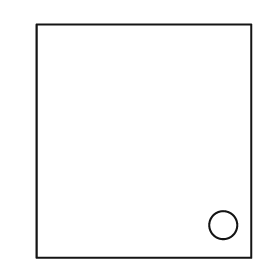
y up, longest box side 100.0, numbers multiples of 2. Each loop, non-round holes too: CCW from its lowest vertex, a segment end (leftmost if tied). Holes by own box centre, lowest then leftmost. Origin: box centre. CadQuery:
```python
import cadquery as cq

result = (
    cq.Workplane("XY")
    .moveTo(-46.0, -50.0)
    .lineTo(46.0, -50.0)
    .lineTo(46.0, 50.0)
    .lineTo(-46.0, 50.0)
    .close()
    .moveTo(34.0, -36.0)
    .circle(6.0)
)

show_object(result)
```